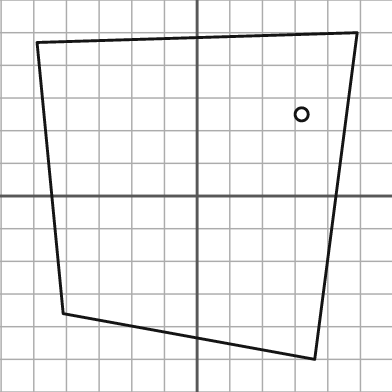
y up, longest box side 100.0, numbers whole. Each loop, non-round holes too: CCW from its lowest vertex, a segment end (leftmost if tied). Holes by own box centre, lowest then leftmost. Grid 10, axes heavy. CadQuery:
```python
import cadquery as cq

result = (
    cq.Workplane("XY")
    .moveTo(36.0, -50.0)
    .lineTo(49.0, 50.0)
    .lineTo(-49.0, 47.0)
    .lineTo(-41.0, -36.0)
    .close()
    .moveTo(32.0, 25.0)
    .circle(2.0)
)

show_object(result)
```